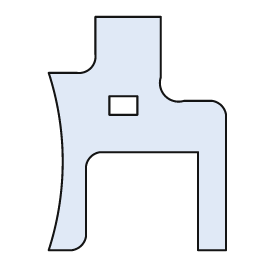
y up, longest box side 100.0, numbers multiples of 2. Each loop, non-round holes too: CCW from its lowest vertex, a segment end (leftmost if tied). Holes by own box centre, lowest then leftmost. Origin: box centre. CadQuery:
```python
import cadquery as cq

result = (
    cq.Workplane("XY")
    .moveTo(-38.0, -50.0)
    .lineTo(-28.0, -50.0)
    .threePointArc((-24.0, -48.0), (-22.0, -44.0))
    .lineTo(-22.0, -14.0)
    .threePointArc((-20.0, -10.0), (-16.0, -8.0))
    .lineTo(26.0, -8.0)
    .lineTo(26.0, -50.0)
    .lineTo(38.0, -50.0)
    .lineTo(38.0, 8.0)
    .threePointArc((36.0, 12.0), (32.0, 14.0))
    .lineTo(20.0, 14.0)
    .threePointArc((12.0, 16.0), (10.0, 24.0))
    .lineTo(10.0, 50.0)
    .lineTo(-18.0, 50.0)
    .lineTo(-18.0, 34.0)
    .threePointArc((-20.0, 28.0), (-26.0, 26.0))
    .lineTo(-38.0, 26.0)
    .threePointArc((-32.0, -12.0), (-38.0, -50.0))
    .close()
    .moveTo(-12.0, 8.0)
    .lineTo(0.0, 8.0)
    .lineTo(0.0, 16.0)
    .lineTo(-12.0, 16.0)
    .close()
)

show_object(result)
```